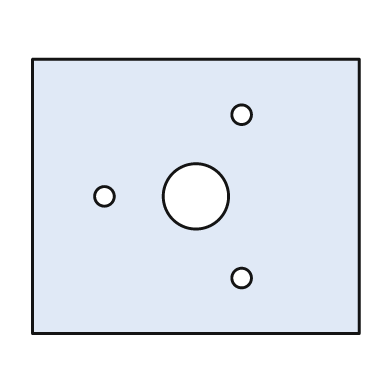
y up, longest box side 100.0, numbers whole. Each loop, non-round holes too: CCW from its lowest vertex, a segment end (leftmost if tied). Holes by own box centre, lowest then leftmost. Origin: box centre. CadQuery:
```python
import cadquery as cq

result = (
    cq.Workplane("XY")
    .moveTo(-50.0, -42.0)
    .lineTo(50.0, -42.0)
    .lineTo(50.0, 42.0)
    .lineTo(-50.0, 42.0)
    .close()
    .moveTo(14.0, -25.0)
    .circle(3.0)
    .moveTo(-28.0, 0.0)
    .circle(3.0)
    .moveTo(0.0, 0.0)
    .circle(10.0)
    .moveTo(14.0, 25.0)
    .circle(3.0)
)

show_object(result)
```